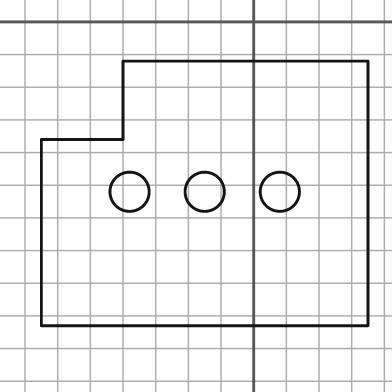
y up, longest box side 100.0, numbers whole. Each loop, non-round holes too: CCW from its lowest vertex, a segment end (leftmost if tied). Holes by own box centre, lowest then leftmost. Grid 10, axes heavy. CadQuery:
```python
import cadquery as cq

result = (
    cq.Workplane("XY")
    .moveTo(-65.0, -93.0)
    .lineTo(35.0, -93.0)
    .lineTo(35.0, -12.0)
    .lineTo(-40.0, -12.0)
    .lineTo(-40.0, -36.0)
    .lineTo(-65.0, -36.0)
    .close()
    .moveTo(-38.0, -52.0)
    .circle(6.0)
    .moveTo(-15.0, -52.0)
    .circle(6.0)
    .moveTo(8.0, -52.0)
    .circle(6.0)
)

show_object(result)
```